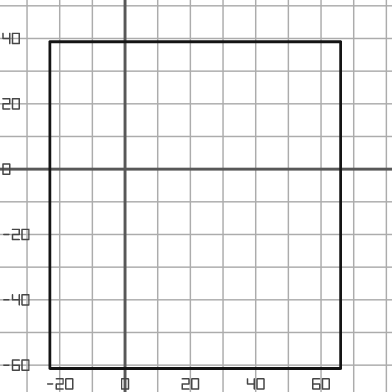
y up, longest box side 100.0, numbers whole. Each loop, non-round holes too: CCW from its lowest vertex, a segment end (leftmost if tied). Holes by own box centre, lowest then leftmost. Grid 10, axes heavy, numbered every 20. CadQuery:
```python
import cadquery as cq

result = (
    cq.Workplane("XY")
    .moveTo(-23.0, -61.0)
    .lineTo(66.0, -61.0)
    .lineTo(66.0, 39.0)
    .lineTo(-23.0, 39.0)
    .close()
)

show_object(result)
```